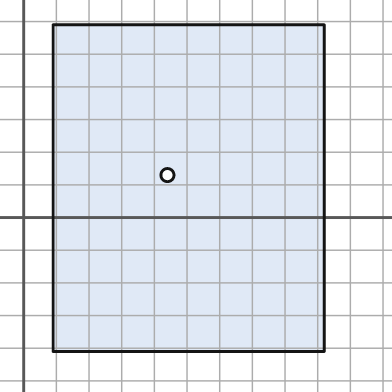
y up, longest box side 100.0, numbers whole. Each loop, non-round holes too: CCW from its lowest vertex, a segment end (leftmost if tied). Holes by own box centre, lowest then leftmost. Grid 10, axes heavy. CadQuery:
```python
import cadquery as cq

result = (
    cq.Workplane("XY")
    .moveTo(9.0, -41.0)
    .lineTo(92.0, -41.0)
    .lineTo(92.0, 59.0)
    .lineTo(9.0, 59.0)
    .close()
    .moveTo(44.0, 13.0)
    .circle(2.0)
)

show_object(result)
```